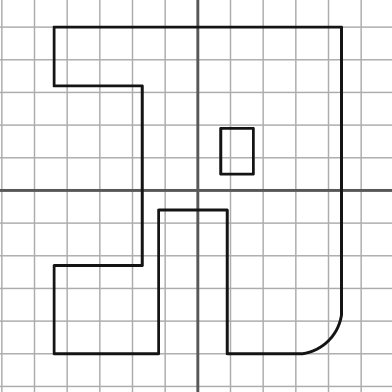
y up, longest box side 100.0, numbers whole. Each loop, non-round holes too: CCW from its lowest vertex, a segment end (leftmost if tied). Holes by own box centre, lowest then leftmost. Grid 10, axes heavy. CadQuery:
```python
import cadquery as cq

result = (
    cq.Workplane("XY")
    .moveTo(-44.0, -50.0)
    .lineTo(-12.0, -50.0)
    .lineTo(-12.0, -6.0)
    .lineTo(9.0, -6.0)
    .lineTo(9.0, -50.0)
    .lineTo(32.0, -50.0)
    .threePointArc((40.0, -46.0), (44.0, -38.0))
    .lineTo(44.0, 50.0)
    .lineTo(-44.0, 50.0)
    .lineTo(-44.0, 32.0)
    .lineTo(-17.0, 32.0)
    .lineTo(-17.0, -23.0)
    .lineTo(-44.0, -23.0)
    .close()
    .moveTo(7.0, 5.0)
    .lineTo(17.0, 5.0)
    .lineTo(17.0, 19.0)
    .lineTo(7.0, 19.0)
    .close()
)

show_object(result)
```